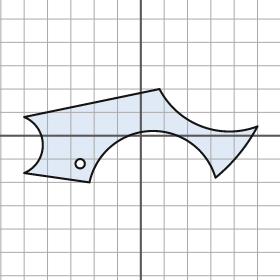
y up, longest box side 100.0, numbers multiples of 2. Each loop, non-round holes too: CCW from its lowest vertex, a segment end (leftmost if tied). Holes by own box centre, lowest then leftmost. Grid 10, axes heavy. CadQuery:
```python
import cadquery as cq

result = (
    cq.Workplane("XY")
    .moveTo(-22.0, -20.0)
    .threePointArc((4.0, 2.0), (32.0, -18.0))
    .threePointArc((42.0, -8.0), (50.0, 4.0))
    .threePointArc((26.0, 4.0), (8.0, 20.0))
    .lineTo(-50.0, 8.0)
    .threePointArc((-42.0, -4.0), (-50.0, -16.0))
    .close()
    .moveTo(-26.0, -12.0)
    .circle(2.0)
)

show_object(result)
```